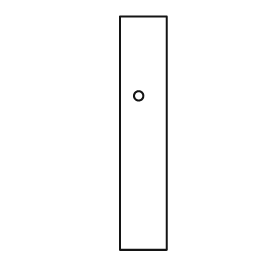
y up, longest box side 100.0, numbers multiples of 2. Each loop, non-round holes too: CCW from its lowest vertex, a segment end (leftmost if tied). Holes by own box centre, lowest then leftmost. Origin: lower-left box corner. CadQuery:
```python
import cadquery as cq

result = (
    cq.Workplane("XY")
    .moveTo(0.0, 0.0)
    .lineTo(20.0, 0.0)
    .lineTo(20.0, 100.0)
    .lineTo(0.0, 100.0)
    .close()
    .moveTo(8.0, 66.0)
    .circle(2.0)
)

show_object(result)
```